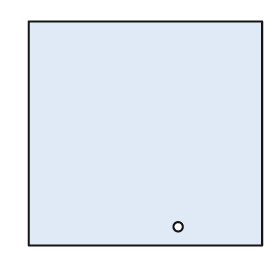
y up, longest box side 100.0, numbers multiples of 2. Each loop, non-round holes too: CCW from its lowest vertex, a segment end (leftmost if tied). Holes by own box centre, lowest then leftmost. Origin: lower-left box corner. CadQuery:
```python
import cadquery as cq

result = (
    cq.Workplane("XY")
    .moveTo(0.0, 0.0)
    .lineTo(100.0, 0.0)
    .lineTo(100.0, 96.0)
    .lineTo(0.0, 96.0)
    .close()
    .moveTo(64.0, 8.0)
    .circle(2.0)
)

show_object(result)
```